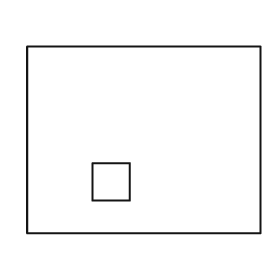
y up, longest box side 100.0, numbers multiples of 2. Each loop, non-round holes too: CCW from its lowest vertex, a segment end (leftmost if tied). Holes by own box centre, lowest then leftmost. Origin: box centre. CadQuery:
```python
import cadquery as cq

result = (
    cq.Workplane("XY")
    .moveTo(-50.0, -40.0)
    .lineTo(50.0, -40.0)
    .lineTo(50.0, 40.0)
    .lineTo(-50.0, 40.0)
    .close()
    .moveTo(-22.0, -26.0)
    .lineTo(-6.0, -26.0)
    .lineTo(-6.0, -10.0)
    .lineTo(-22.0, -10.0)
    .close()
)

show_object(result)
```